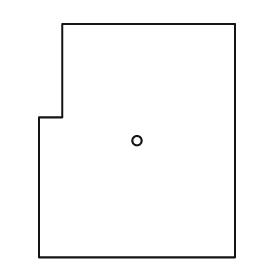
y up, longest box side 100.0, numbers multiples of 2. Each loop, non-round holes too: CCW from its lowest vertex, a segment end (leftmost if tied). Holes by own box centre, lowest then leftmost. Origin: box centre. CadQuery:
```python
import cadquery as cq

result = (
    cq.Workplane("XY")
    .moveTo(-42.0, -50.0)
    .lineTo(42.0, -50.0)
    .lineTo(42.0, 50.0)
    .lineTo(-32.0, 50.0)
    .lineTo(-32.0, 10.0)
    .lineTo(-42.0, 10.0)
    .close()
    .moveTo(0.0, 0.0)
    .circle(2.0)
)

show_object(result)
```